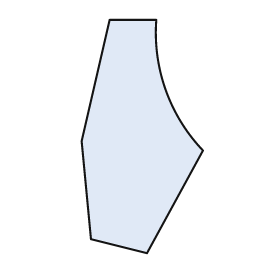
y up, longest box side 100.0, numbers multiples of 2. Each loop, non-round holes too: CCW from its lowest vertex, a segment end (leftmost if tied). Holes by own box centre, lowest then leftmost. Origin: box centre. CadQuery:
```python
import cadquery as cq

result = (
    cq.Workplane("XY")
    .moveTo(2.0, -50.0)
    .lineTo(26.0, -6.0)
    .threePointArc((10.0, 20.0), (6.0, 50.0))
    .lineTo(-14.0, 50.0)
    .lineTo(-26.0, -2.0)
    .lineTo(-22.0, -44.0)
    .close()
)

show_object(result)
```